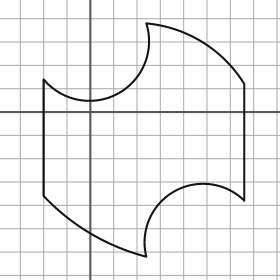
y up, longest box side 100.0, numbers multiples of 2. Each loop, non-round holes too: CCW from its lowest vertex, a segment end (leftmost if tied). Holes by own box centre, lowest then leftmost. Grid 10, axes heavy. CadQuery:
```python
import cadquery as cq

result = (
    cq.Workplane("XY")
    .moveTo(24.0, -62.0)
    .threePointArc((36.0, -34.0), (66.0, -38.0))
    .lineTo(66.0, 12.0)
    .threePointArc((48.0, 30.0), (24.0, 38.0))
    .threePointArc((12.0, 8.0), (-20.0, 14.0))
    .lineTo(-20.0, -36.0)
    .threePointArc((0.0, -52.0), (24.0, -62.0))
    .close()
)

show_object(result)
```